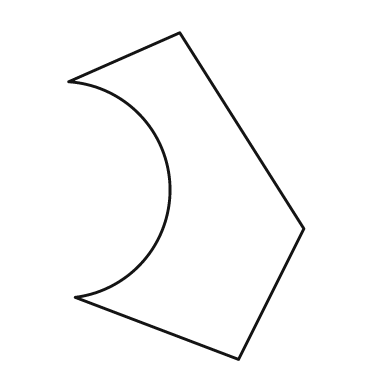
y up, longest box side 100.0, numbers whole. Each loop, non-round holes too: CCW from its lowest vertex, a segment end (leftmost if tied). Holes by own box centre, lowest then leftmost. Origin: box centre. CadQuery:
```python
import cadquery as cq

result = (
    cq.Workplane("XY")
    .moveTo(16.0, -50.0)
    .lineTo(36.0, -10.0)
    .lineTo(-2.0, 50.0)
    .lineTo(-36.0, 35.0)
    .threePointArc((-5.0, 3.0), (-34.0, -31.0))
    .close()
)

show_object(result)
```